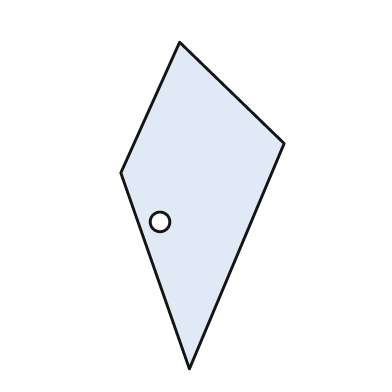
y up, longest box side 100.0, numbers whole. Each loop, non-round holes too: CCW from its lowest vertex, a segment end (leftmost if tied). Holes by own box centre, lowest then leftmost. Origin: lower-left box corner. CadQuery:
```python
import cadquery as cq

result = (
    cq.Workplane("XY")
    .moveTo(21.0, 0.0)
    .lineTo(50.0, 69.0)
    .lineTo(18.0, 100.0)
    .lineTo(0.0, 60.0)
    .close()
    .moveTo(12.0, 45.0)
    .circle(3.0)
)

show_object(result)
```